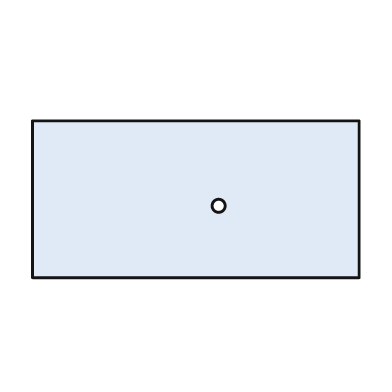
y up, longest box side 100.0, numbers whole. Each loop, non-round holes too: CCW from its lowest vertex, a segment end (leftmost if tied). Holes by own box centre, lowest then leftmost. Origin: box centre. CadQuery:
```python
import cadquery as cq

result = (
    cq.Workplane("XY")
    .moveTo(-50.0, -24.0)
    .lineTo(50.0, -24.0)
    .lineTo(50.0, 24.0)
    .lineTo(-50.0, 24.0)
    .close()
    .moveTo(7.0, -2.0)
    .circle(2.0)
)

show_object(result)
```